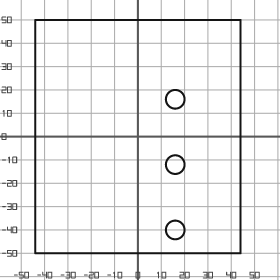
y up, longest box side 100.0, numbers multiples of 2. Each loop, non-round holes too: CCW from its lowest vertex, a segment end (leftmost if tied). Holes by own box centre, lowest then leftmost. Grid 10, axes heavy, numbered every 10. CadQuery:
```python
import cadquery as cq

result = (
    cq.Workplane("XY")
    .moveTo(-44.0, -50.0)
    .lineTo(44.0, -50.0)
    .lineTo(44.0, 50.0)
    .lineTo(-44.0, 50.0)
    .close()
    .moveTo(16.0, -40.0)
    .circle(4.0)
    .moveTo(16.0, -12.0)
    .circle(4.0)
    .moveTo(16.0, 16.0)
    .circle(4.0)
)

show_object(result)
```